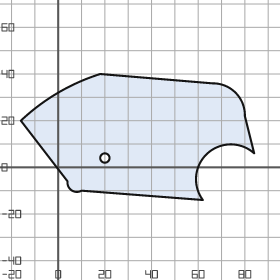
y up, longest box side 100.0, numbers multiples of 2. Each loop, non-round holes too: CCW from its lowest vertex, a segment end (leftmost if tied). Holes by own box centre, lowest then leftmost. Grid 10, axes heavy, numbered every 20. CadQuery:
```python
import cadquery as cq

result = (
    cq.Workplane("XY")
    .moveTo(62.0, -14.0)
    .threePointArc((64.0, 6.0), (84.0, 6.0))
    .lineTo(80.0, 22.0)
    .threePointArc((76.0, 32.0), (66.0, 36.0))
    .lineTo(18.0, 40.0)
    .threePointArc((0.0, 32.0), (-16.0, 20.0))
    .lineTo(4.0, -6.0)
    .threePointArc((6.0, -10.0), (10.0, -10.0))
    .close()
    .moveTo(20.0, 4.0)
    .circle(2.0)
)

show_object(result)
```